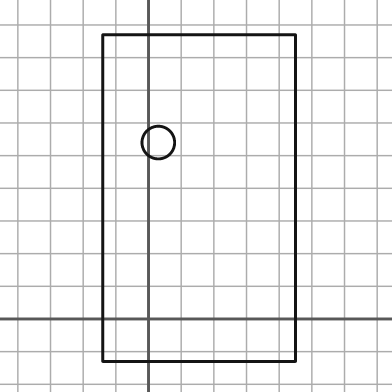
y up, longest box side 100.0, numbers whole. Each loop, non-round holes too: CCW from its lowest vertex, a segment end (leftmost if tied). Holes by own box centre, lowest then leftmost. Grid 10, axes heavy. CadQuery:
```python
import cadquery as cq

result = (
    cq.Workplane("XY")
    .moveTo(-14.0, -13.0)
    .lineTo(45.0, -13.0)
    .lineTo(45.0, 87.0)
    .lineTo(-14.0, 87.0)
    .close()
    .moveTo(3.0, 54.0)
    .circle(5.0)
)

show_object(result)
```